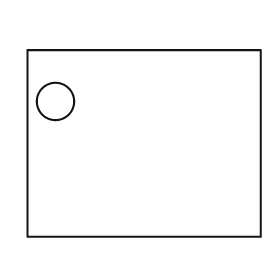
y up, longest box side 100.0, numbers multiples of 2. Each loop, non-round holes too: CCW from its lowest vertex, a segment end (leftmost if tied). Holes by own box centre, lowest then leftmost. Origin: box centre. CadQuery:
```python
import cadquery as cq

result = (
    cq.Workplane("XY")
    .moveTo(-50.0, -40.0)
    .lineTo(50.0, -40.0)
    .lineTo(50.0, 40.0)
    .lineTo(-50.0, 40.0)
    .close()
    .moveTo(-38.0, 18.0)
    .circle(8.0)
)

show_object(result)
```